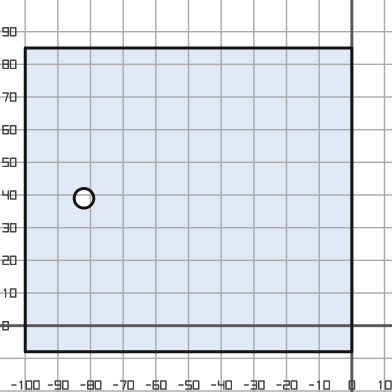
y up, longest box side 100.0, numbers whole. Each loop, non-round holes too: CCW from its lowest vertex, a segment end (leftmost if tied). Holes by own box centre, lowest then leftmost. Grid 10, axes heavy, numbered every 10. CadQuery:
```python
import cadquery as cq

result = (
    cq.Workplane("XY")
    .moveTo(-100.0, -8.0)
    .lineTo(0.0, -8.0)
    .lineTo(0.0, 85.0)
    .lineTo(-100.0, 85.0)
    .close()
    .moveTo(-82.0, 39.0)
    .circle(3.0)
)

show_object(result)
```